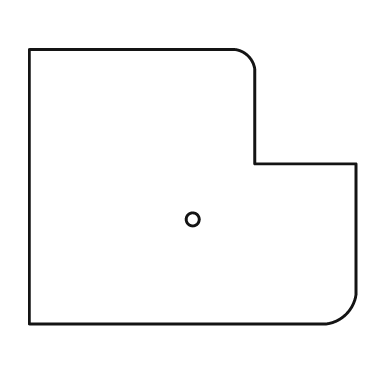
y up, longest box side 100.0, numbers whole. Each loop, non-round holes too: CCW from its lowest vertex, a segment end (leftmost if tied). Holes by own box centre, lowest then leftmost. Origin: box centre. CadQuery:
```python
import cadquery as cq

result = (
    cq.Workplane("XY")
    .moveTo(-50.0, -42.0)
    .lineTo(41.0, -42.0)
    .threePointArc((47.0, -39.0), (50.0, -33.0))
    .lineTo(50.0, 7.0)
    .lineTo(19.0, 7.0)
    .lineTo(19.0, 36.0)
    .threePointArc((17.0, 40.0), (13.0, 42.0))
    .lineTo(-50.0, 42.0)
    .close()
    .moveTo(0.0, -10.0)
    .circle(2.0)
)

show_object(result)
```